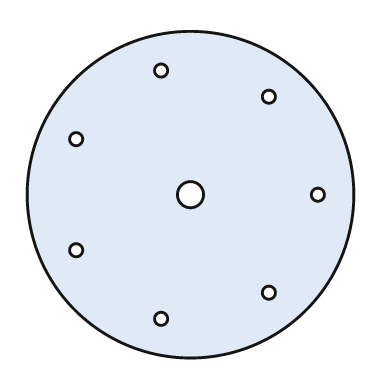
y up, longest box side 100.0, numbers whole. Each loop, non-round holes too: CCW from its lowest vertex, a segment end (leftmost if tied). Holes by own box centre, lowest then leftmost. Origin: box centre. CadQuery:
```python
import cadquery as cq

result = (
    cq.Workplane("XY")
    .moveTo(0.0, 0.0)
    .circle(50.0)
    .moveTo(-9.0, -38.0)
    .circle(2.0)
    .moveTo(24.0, -30.0)
    .circle(2.0)
    .moveTo(-35.0, -17.0)
    .circle(2.0)
    .moveTo(0.0, 0.0)
    .circle(4.0)
    .moveTo(39.0, 0.0)
    .circle(2.0)
    .moveTo(-35.0, 17.0)
    .circle(2.0)
    .moveTo(24.0, 30.0)
    .circle(2.0)
    .moveTo(-9.0, 38.0)
    .circle(2.0)
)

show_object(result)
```